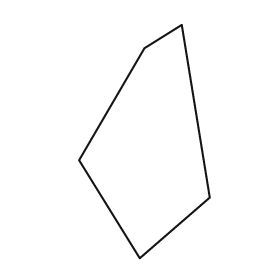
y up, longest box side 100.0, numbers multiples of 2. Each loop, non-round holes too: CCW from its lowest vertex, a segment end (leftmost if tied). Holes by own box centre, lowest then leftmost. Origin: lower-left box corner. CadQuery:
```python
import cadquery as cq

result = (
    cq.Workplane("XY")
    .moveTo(26.0, 0.0)
    .lineTo(56.0, 26.0)
    .lineTo(44.0, 100.0)
    .lineTo(28.0, 90.0)
    .lineTo(0.0, 42.0)
    .close()
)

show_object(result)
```